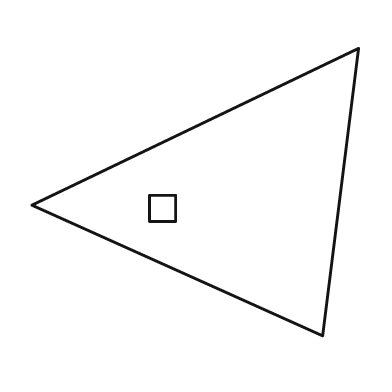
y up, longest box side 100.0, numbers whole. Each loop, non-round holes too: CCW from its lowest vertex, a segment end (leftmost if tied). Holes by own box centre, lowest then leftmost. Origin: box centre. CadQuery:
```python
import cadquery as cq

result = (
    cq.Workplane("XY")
    .moveTo(39.0, -44.0)
    .lineTo(50.0, 44.0)
    .lineTo(-50.0, -4.0)
    .close()
    .moveTo(-14.0, -9.0)
    .lineTo(-6.0, -9.0)
    .lineTo(-6.0, -1.0)
    .lineTo(-14.0, -1.0)
    .close()
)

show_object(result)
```